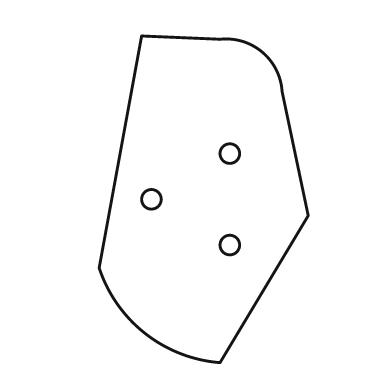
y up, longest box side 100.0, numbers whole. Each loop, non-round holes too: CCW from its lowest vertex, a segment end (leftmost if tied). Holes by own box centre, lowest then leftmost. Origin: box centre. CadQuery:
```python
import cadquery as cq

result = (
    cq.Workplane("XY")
    .moveTo(5.0, -50.0)
    .lineTo(32.0, -5.0)
    .lineTo(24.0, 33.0)
    .threePointArc((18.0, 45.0), (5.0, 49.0))
    .lineTo(-19.0, 50.0)
    .lineTo(-32.0, -21.0)
    .threePointArc((-18.0, -41.0), (5.0, -50.0))
    .close()
    .moveTo(8.0, -14.0)
    .circle(3.0)
    .moveTo(-16.0, 0.0)
    .circle(3.0)
    .moveTo(8.0, 14.0)
    .circle(3.0)
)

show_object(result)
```